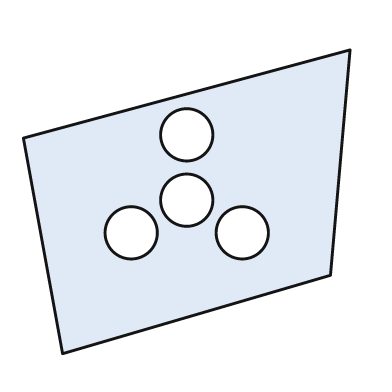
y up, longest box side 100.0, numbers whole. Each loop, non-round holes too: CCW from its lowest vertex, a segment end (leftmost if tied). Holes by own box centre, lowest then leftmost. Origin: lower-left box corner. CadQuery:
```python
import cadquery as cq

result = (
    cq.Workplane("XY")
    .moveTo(12.0, 0.0)
    .lineTo(94.0, 24.0)
    .lineTo(100.0, 93.0)
    .lineTo(0.0, 66.0)
    .close()
    .moveTo(33.0, 37.0)
    .circle(8.0)
    .moveTo(67.0, 37.0)
    .circle(8.0)
    .moveTo(50.0, 47.0)
    .circle(8.0)
    .moveTo(50.0, 67.0)
    .circle(8.0)
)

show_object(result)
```